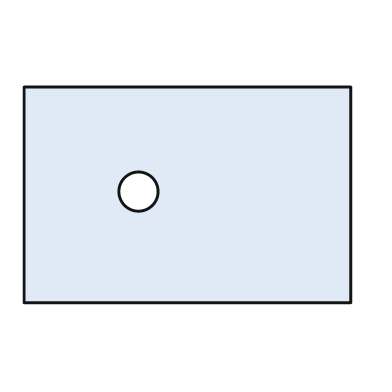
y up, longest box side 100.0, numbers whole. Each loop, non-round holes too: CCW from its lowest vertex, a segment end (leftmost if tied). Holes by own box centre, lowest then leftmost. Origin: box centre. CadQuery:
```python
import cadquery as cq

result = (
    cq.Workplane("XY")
    .moveTo(-50.0, -33.0)
    .lineTo(50.0, -33.0)
    .lineTo(50.0, 33.0)
    .lineTo(-50.0, 33.0)
    .close()
    .moveTo(-15.0, 1.0)
    .circle(6.0)
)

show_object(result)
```